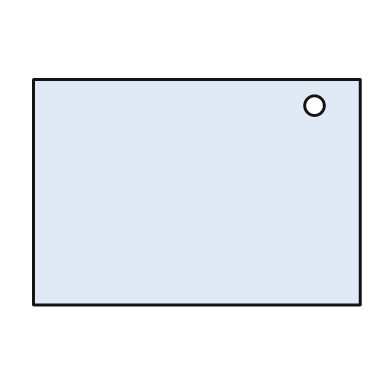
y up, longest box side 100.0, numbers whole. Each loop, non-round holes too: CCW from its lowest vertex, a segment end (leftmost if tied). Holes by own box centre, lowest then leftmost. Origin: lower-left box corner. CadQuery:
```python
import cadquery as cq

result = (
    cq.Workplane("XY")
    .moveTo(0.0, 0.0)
    .lineTo(100.0, 0.0)
    .lineTo(100.0, 69.0)
    .lineTo(0.0, 69.0)
    .close()
    .moveTo(86.0, 61.0)
    .circle(3.0)
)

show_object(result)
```